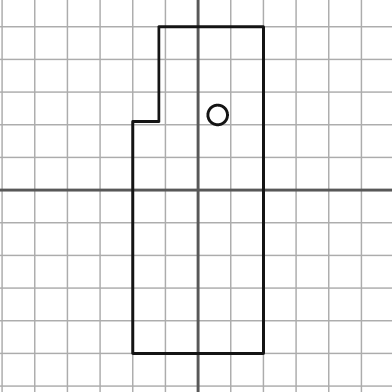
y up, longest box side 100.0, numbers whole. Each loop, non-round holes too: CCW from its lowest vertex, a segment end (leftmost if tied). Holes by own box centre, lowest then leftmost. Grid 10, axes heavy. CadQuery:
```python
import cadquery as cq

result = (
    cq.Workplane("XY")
    .moveTo(-20.0, -50.0)
    .lineTo(20.0, -50.0)
    .lineTo(20.0, 50.0)
    .lineTo(-12.0, 50.0)
    .lineTo(-12.0, 21.0)
    .lineTo(-20.0, 21.0)
    .close()
    .moveTo(6.0, 23.0)
    .circle(3.0)
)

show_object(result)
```